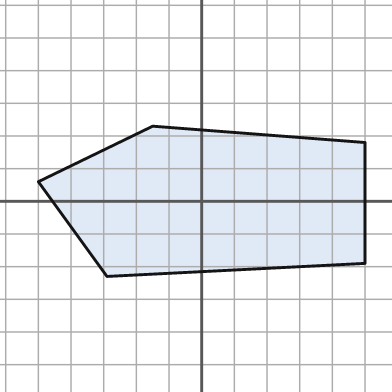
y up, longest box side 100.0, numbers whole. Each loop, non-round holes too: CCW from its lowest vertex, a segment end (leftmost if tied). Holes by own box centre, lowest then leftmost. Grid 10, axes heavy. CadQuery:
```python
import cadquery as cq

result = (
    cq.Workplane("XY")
    .moveTo(-29.0, -23.0)
    .lineTo(50.0, -19.0)
    .lineTo(50.0, 18.0)
    .lineTo(-15.0, 23.0)
    .lineTo(-50.0, 6.0)
    .close()
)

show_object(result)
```